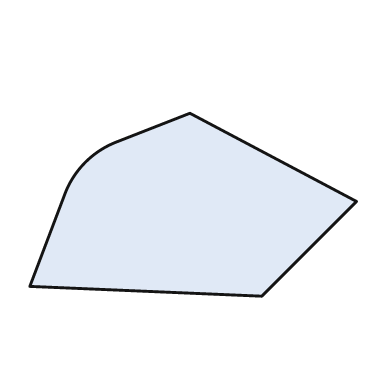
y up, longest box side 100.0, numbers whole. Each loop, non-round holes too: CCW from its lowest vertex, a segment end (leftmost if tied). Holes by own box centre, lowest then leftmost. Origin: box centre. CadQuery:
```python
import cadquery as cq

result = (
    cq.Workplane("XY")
    .moveTo(21.0, -28.0)
    .lineTo(50.0, 1.0)
    .lineTo(-1.0, 28.0)
    .lineTo(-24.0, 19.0)
    .threePointArc((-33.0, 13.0), (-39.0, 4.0))
    .lineTo(-50.0, -25.0)
    .close()
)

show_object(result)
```